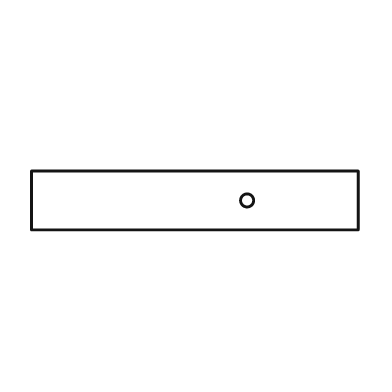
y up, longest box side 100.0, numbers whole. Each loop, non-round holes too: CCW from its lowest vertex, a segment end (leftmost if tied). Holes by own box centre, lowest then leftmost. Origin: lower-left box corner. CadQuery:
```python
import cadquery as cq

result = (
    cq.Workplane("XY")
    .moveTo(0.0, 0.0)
    .lineTo(100.0, 0.0)
    .lineTo(100.0, 18.0)
    .lineTo(0.0, 18.0)
    .close()
    .moveTo(66.0, 9.0)
    .circle(2.0)
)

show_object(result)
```